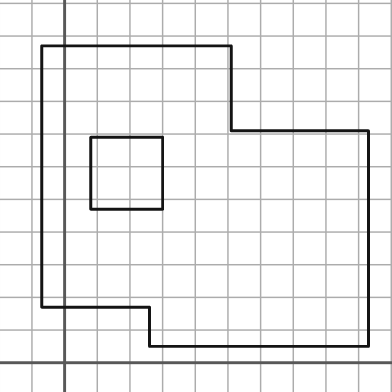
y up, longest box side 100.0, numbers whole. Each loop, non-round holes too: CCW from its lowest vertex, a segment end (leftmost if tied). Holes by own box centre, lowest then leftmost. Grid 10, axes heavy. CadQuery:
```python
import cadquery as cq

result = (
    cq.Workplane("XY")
    .moveTo(26.0, 5.0)
    .lineTo(93.0, 5.0)
    .lineTo(93.0, 71.0)
    .lineTo(51.0, 71.0)
    .lineTo(51.0, 97.0)
    .lineTo(-7.0, 97.0)
    .lineTo(-7.0, 17.0)
    .lineTo(26.0, 17.0)
    .close()
    .moveTo(8.0, 47.0)
    .lineTo(30.0, 47.0)
    .lineTo(30.0, 69.0)
    .lineTo(8.0, 69.0)
    .close()
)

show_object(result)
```